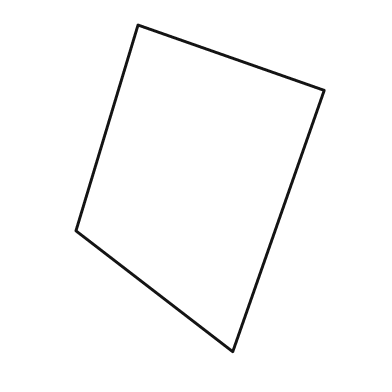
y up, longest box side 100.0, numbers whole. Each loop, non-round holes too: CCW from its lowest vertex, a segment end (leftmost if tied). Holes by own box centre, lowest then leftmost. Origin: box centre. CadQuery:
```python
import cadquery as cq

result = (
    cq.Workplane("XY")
    .moveTo(10.0, -50.0)
    .lineTo(38.0, 30.0)
    .lineTo(-19.0, 50.0)
    .lineTo(-38.0, -13.0)
    .close()
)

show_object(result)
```